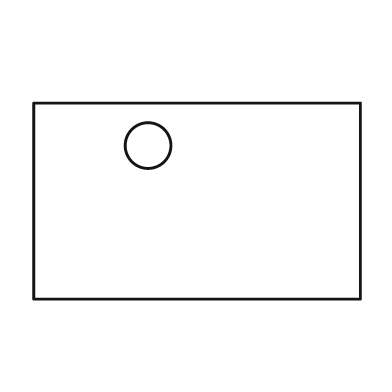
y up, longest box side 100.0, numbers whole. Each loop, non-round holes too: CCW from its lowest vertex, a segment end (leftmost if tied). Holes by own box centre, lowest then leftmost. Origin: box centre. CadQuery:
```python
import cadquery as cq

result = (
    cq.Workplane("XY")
    .moveTo(-50.0, -30.0)
    .lineTo(50.0, -30.0)
    .lineTo(50.0, 30.0)
    .lineTo(-50.0, 30.0)
    .close()
    .moveTo(-15.0, 17.0)
    .circle(7.0)
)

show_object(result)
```